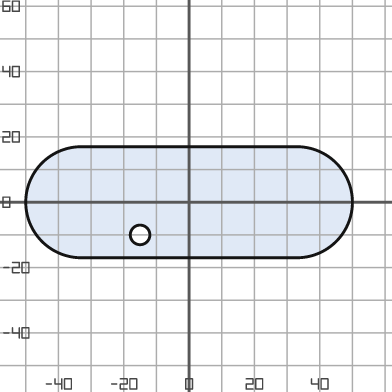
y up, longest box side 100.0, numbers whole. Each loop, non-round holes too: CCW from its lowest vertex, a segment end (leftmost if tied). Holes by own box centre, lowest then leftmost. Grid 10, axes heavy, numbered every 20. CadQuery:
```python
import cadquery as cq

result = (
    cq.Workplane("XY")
    .moveTo(-33.0, -17.0)
    .lineTo(33.0, -17.0)
    .threePointArc((50.0, 0.0), (33.0, 17.0))
    .lineTo(-33.0, 17.0)
    .threePointArc((-50.0, 0.0), (-33.0, -17.0))
    .close()
    .moveTo(-15.0, -10.0)
    .circle(3.0)
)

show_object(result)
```